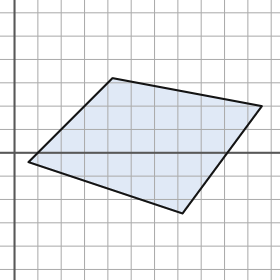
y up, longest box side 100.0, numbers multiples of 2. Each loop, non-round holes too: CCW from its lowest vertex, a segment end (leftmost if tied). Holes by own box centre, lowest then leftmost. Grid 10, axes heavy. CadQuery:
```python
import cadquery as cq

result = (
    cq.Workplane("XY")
    .moveTo(72.0, -26.0)
    .lineTo(106.0, 20.0)
    .lineTo(42.0, 32.0)
    .lineTo(6.0, -4.0)
    .close()
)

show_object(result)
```